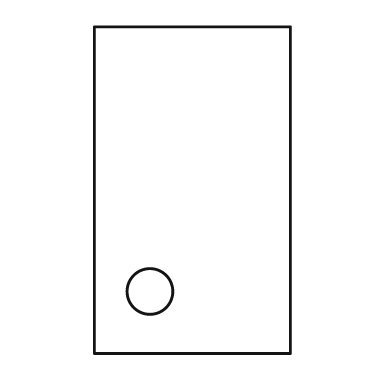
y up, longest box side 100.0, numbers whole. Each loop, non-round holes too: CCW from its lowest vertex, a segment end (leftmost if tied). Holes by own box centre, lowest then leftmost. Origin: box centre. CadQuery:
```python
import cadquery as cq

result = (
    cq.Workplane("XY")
    .moveTo(-30.0, -50.0)
    .lineTo(30.0, -50.0)
    .lineTo(30.0, 50.0)
    .lineTo(-30.0, 50.0)
    .close()
    .moveTo(-13.0, -31.0)
    .circle(7.0)
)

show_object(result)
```